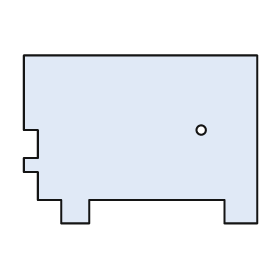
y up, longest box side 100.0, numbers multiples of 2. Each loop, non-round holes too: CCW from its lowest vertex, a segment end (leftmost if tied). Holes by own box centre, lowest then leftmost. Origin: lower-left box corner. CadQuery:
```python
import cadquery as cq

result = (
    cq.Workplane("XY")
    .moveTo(16.0, 0.0)
    .lineTo(28.0, 0.0)
    .lineTo(28.0, 10.0)
    .lineTo(86.0, 10.0)
    .lineTo(86.0, 0.0)
    .lineTo(100.0, 0.0)
    .lineTo(100.0, 72.0)
    .lineTo(0.0, 72.0)
    .lineTo(0.0, 40.0)
    .lineTo(6.0, 40.0)
    .lineTo(6.0, 28.0)
    .lineTo(0.0, 28.0)
    .lineTo(0.0, 22.0)
    .lineTo(6.0, 22.0)
    .lineTo(6.0, 10.0)
    .lineTo(16.0, 10.0)
    .close()
    .moveTo(76.0, 40.0)
    .circle(2.0)
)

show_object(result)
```